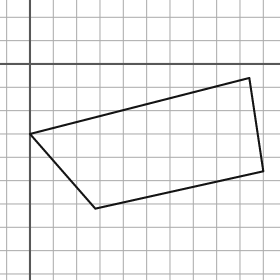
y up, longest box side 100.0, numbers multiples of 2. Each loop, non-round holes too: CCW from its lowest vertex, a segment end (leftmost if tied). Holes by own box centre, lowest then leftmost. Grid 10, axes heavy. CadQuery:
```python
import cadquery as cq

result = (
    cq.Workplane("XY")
    .moveTo(28.0, -62.0)
    .lineTo(100.0, -46.0)
    .lineTo(94.0, -6.0)
    .lineTo(0.0, -30.0)
    .close()
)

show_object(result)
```